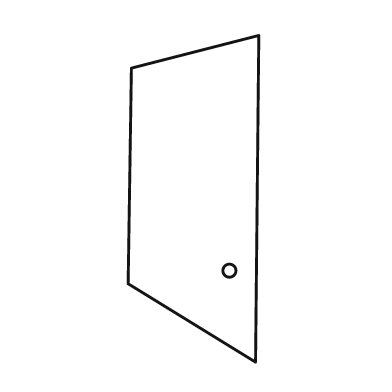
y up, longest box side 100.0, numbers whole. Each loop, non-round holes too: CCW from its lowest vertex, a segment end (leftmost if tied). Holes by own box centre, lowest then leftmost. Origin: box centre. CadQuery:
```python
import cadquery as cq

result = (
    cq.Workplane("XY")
    .moveTo(19.0, -50.0)
    .lineTo(20.0, 50.0)
    .lineTo(-19.0, 40.0)
    .lineTo(-20.0, -26.0)
    .close()
    .moveTo(11.0, -22.0)
    .circle(2.0)
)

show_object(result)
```